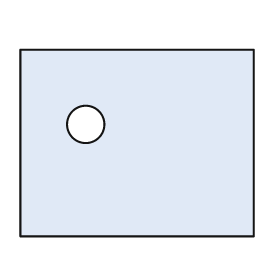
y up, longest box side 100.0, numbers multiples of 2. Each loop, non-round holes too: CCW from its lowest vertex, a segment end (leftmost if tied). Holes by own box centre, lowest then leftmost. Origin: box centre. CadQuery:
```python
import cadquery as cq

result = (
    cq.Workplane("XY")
    .moveTo(-50.0, -40.0)
    .lineTo(50.0, -40.0)
    .lineTo(50.0, 40.0)
    .lineTo(-50.0, 40.0)
    .close()
    .moveTo(-22.0, 8.0)
    .circle(8.0)
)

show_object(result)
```